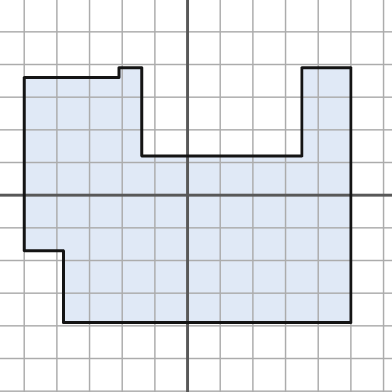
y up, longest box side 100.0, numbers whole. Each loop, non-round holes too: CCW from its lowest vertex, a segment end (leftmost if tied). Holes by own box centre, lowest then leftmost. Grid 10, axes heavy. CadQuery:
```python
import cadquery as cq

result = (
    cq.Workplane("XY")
    .moveTo(-38.0, -39.0)
    .lineTo(50.0, -39.0)
    .lineTo(50.0, 39.0)
    .lineTo(35.0, 39.0)
    .lineTo(35.0, 12.0)
    .lineTo(-14.0, 12.0)
    .lineTo(-14.0, 39.0)
    .lineTo(-21.0, 39.0)
    .lineTo(-21.0, 36.0)
    .lineTo(-50.0, 36.0)
    .lineTo(-50.0, -17.0)
    .lineTo(-38.0, -17.0)
    .close()
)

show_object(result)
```